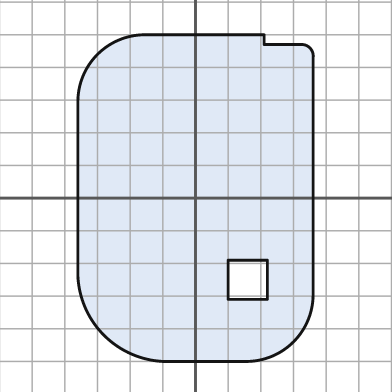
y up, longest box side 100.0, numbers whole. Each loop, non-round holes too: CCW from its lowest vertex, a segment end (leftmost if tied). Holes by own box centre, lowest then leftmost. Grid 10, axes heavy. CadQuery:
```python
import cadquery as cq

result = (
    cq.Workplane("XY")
    .moveTo(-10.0, -50.0)
    .lineTo(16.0, -50.0)
    .threePointArc((30.0, -44.0), (36.0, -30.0))
    .lineTo(36.0, 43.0)
    .threePointArc((35.0, 46.0), (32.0, 47.0))
    .lineTo(21.0, 47.0)
    .lineTo(21.0, 50.0)
    .lineTo(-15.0, 50.0)
    .threePointArc((-30.0, 44.0), (-36.0, 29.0))
    .lineTo(-36.0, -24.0)
    .threePointArc((-28.0, -42.0), (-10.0, -50.0))
    .close()
    .moveTo(10.0, -31.0)
    .lineTo(22.0, -31.0)
    .lineTo(22.0, -19.0)
    .lineTo(10.0, -19.0)
    .close()
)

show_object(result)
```